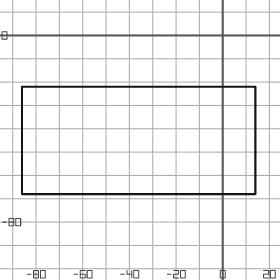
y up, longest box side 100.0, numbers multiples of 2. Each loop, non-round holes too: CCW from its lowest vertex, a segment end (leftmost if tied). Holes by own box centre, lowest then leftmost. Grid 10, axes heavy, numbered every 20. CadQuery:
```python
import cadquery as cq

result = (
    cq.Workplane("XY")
    .moveTo(-86.0, -68.0)
    .lineTo(14.0, -68.0)
    .lineTo(14.0, -22.0)
    .lineTo(-86.0, -22.0)
    .close()
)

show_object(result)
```